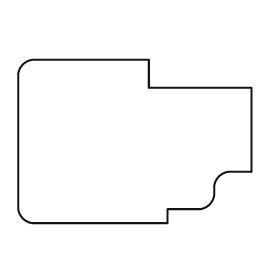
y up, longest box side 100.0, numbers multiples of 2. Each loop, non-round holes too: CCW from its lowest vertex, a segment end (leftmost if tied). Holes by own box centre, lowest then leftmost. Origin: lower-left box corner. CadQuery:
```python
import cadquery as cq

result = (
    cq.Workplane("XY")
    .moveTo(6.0, 0.0)
    .lineTo(64.0, 0.0)
    .lineTo(64.0, 6.0)
    .lineTo(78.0, 6.0)
    .threePointArc((82.0, 8.0), (84.0, 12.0))
    .lineTo(84.0, 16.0)
    .threePointArc((86.0, 20.0), (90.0, 22.0))
    .lineTo(100.0, 22.0)
    .lineTo(100.0, 58.0)
    .lineTo(56.0, 58.0)
    .lineTo(56.0, 70.0)
    .lineTo(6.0, 70.0)
    .threePointArc((2.0, 68.0), (0.0, 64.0))
    .lineTo(0.0, 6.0)
    .threePointArc((2.0, 2.0), (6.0, 0.0))
    .close()
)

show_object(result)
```